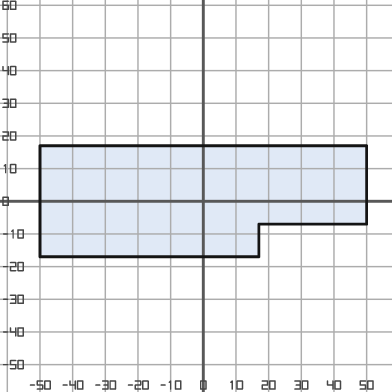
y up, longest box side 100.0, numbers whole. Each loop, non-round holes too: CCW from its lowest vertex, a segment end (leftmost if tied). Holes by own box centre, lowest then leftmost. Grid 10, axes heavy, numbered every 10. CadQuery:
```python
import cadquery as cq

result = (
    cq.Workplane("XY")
    .moveTo(-50.0, -17.0)
    .lineTo(17.0, -17.0)
    .lineTo(17.0, -7.0)
    .lineTo(50.0, -7.0)
    .lineTo(50.0, 17.0)
    .lineTo(-50.0, 17.0)
    .close()
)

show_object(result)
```